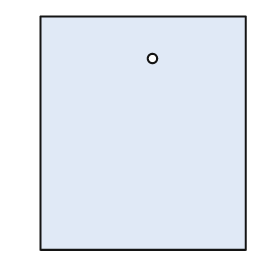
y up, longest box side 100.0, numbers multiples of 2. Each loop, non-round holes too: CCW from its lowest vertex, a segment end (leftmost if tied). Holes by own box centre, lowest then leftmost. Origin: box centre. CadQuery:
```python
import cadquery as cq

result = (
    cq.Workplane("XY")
    .moveTo(-44.0, -50.0)
    .lineTo(44.0, -50.0)
    .lineTo(44.0, 50.0)
    .lineTo(-44.0, 50.0)
    .close()
    .moveTo(4.0, 32.0)
    .circle(2.0)
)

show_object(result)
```